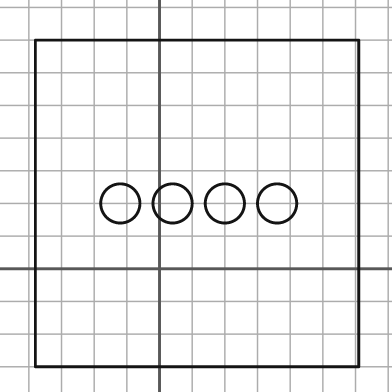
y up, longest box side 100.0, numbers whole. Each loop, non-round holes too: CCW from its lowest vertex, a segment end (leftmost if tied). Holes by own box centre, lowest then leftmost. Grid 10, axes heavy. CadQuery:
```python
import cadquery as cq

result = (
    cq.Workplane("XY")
    .moveTo(-38.0, -30.0)
    .lineTo(61.0, -30.0)
    .lineTo(61.0, 70.0)
    .lineTo(-38.0, 70.0)
    .close()
    .moveTo(-12.0, 20.0)
    .circle(6.0)
    .moveTo(4.0, 20.0)
    .circle(6.0)
    .moveTo(20.0, 20.0)
    .circle(6.0)
    .moveTo(36.0, 20.0)
    .circle(6.0)
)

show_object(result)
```